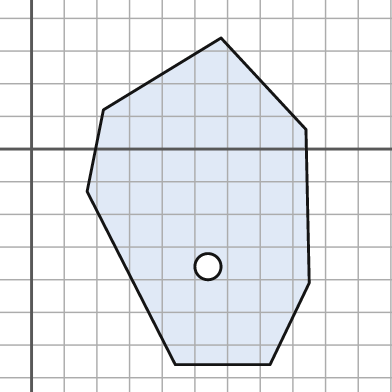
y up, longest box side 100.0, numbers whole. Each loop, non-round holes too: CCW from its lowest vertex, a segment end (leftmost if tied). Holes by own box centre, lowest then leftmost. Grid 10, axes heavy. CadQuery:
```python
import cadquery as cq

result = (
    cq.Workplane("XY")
    .moveTo(44.0, -66.0)
    .lineTo(73.0, -66.0)
    .lineTo(85.0, -41.0)
    .lineTo(84.0, 6.0)
    .lineTo(58.0, 34.0)
    .lineTo(22.0, 12.0)
    .lineTo(17.0, -13.0)
    .close()
    .moveTo(54.0, -36.0)
    .circle(4.0)
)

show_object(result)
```